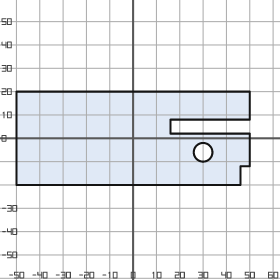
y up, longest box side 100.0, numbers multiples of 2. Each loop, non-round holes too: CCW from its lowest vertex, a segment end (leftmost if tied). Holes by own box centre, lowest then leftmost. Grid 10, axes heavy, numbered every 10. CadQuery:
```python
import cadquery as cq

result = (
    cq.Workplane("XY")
    .moveTo(-50.0, -20.0)
    .lineTo(46.0, -20.0)
    .lineTo(46.0, -12.0)
    .lineTo(50.0, -12.0)
    .lineTo(50.0, 2.0)
    .lineTo(16.0, 2.0)
    .lineTo(16.0, 8.0)
    .lineTo(50.0, 8.0)
    .lineTo(50.0, 20.0)
    .lineTo(-50.0, 20.0)
    .close()
    .moveTo(30.0, -6.0)
    .circle(4.0)
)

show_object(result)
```